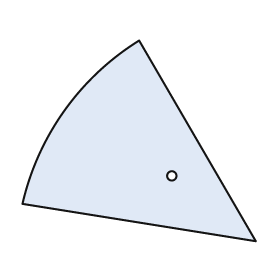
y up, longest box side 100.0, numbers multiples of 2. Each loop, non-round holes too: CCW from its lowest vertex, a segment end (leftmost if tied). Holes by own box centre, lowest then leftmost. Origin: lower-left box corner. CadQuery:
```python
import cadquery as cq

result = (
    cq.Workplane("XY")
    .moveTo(100.0, 0.0)
    .lineTo(50.0, 86.0)
    .threePointArc((18.0, 56.0), (0.0, 16.0))
    .close()
    .moveTo(64.0, 28.0)
    .circle(2.0)
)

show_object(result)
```